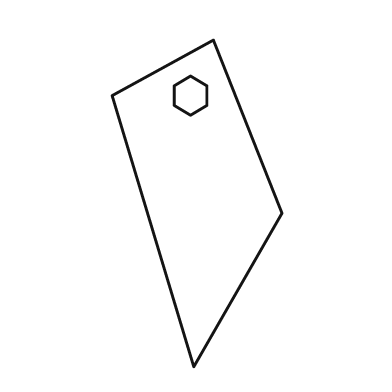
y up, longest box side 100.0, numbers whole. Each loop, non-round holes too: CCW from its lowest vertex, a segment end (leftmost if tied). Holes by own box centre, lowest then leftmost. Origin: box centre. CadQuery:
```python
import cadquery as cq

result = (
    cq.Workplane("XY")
    .moveTo(-1.0, -50.0)
    .lineTo(26.0, -3.0)
    .lineTo(5.0, 50.0)
    .lineTo(-26.0, 33.0)
    .close()
    .moveTo(-2.0, 27.0)
    .lineTo(3.0, 30.0)
    .lineTo(3.0, 36.0)
    .lineTo(-2.0, 39.0)
    .lineTo(-7.0, 36.0)
    .lineTo(-7.0, 30.0)
    .close()
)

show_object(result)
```